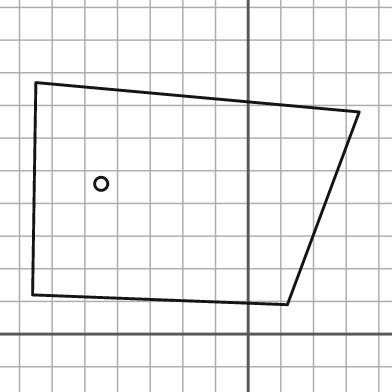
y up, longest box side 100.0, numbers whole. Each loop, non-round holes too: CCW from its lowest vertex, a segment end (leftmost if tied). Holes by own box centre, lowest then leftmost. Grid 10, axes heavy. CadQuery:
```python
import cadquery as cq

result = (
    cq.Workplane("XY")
    .moveTo(12.0, 9.0)
    .lineTo(34.0, 68.0)
    .lineTo(-65.0, 77.0)
    .lineTo(-66.0, 12.0)
    .close()
    .moveTo(-45.0, 46.0)
    .circle(2.0)
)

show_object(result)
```